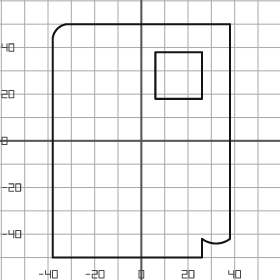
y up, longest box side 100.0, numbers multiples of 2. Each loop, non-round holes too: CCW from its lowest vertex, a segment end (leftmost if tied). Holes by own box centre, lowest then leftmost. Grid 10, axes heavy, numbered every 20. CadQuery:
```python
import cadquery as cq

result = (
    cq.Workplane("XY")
    .moveTo(-38.0, -50.0)
    .lineTo(26.0, -50.0)
    .lineTo(26.0, -42.0)
    .threePointArc((32.0, -44.0), (38.0, -42.0))
    .lineTo(38.0, 50.0)
    .lineTo(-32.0, 50.0)
    .threePointArc((-36.0, 48.0), (-38.0, 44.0))
    .close()
    .moveTo(6.0, 18.0)
    .lineTo(26.0, 18.0)
    .lineTo(26.0, 38.0)
    .lineTo(6.0, 38.0)
    .close()
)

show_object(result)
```